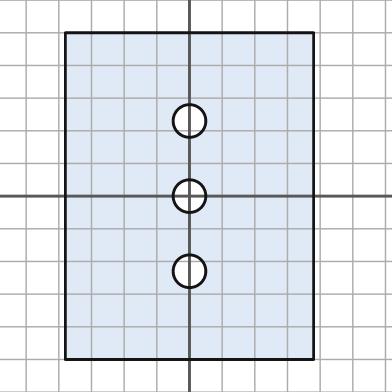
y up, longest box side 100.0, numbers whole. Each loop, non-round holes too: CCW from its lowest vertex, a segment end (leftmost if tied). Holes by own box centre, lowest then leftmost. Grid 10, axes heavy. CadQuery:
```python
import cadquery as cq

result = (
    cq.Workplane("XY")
    .moveTo(-38.0, -50.0)
    .lineTo(38.0, -50.0)
    .lineTo(38.0, 50.0)
    .lineTo(-38.0, 50.0)
    .close()
    .moveTo(0.0, -23.0)
    .circle(5.0)
    .moveTo(0.0, 0.0)
    .circle(5.0)
    .moveTo(0.0, 23.0)
    .circle(5.0)
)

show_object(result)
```